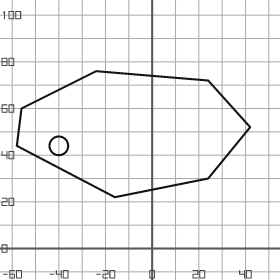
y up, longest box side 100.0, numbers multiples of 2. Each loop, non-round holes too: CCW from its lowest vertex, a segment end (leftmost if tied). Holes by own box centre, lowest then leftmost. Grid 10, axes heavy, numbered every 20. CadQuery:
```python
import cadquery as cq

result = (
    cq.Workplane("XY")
    .moveTo(-16.0, 22.0)
    .lineTo(24.0, 30.0)
    .lineTo(42.0, 52.0)
    .lineTo(24.0, 72.0)
    .lineTo(-24.0, 76.0)
    .lineTo(-56.0, 60.0)
    .lineTo(-58.0, 44.0)
    .close()
    .moveTo(-40.0, 44.0)
    .circle(4.0)
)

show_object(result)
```